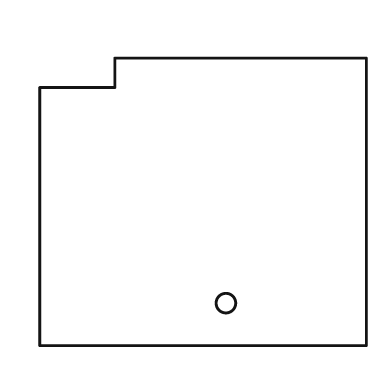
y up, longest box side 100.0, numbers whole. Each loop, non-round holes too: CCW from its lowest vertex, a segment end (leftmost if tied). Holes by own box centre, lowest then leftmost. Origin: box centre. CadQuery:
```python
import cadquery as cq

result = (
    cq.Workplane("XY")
    .moveTo(-50.0, -44.0)
    .lineTo(50.0, -44.0)
    .lineTo(50.0, 44.0)
    .lineTo(-27.0, 44.0)
    .lineTo(-27.0, 35.0)
    .lineTo(-50.0, 35.0)
    .close()
    .moveTo(7.0, -31.0)
    .circle(3.0)
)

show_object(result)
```